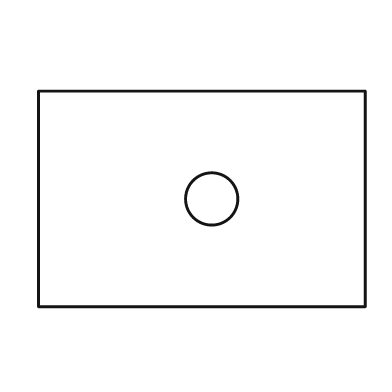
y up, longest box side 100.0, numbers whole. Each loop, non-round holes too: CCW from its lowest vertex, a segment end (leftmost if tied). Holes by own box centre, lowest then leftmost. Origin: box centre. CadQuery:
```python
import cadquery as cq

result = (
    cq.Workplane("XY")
    .moveTo(-50.0, -33.0)
    .lineTo(50.0, -33.0)
    .lineTo(50.0, 33.0)
    .lineTo(-50.0, 33.0)
    .close()
    .moveTo(3.0, 0.0)
    .circle(8.0)
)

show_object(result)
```